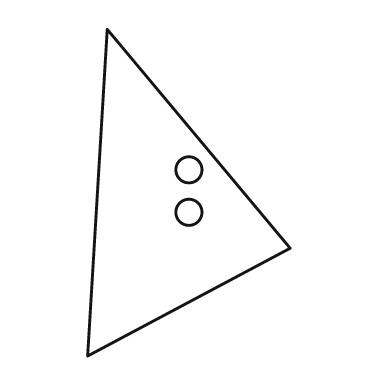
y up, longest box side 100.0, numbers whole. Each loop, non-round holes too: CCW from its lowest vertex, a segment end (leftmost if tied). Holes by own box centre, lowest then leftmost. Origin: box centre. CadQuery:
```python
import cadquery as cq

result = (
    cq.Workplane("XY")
    .moveTo(-31.0, -50.0)
    .lineTo(31.0, -17.0)
    .lineTo(-25.0, 50.0)
    .close()
    .moveTo(0.0, -6.0)
    .circle(4.0)
    .moveTo(0.0, 7.0)
    .circle(4.0)
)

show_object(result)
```